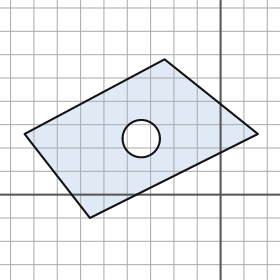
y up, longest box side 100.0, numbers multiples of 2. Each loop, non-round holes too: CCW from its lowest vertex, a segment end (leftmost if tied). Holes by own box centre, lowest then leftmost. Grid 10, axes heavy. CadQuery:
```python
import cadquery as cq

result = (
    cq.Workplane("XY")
    .moveTo(-56.0, -10.0)
    .lineTo(16.0, 26.0)
    .lineTo(-24.0, 58.0)
    .lineTo(-84.0, 26.0)
    .close()
    .moveTo(-34.0, 24.0)
    .circle(8.0)
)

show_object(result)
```